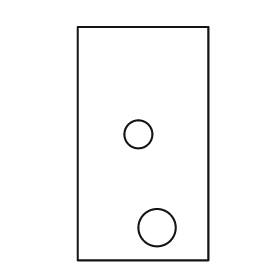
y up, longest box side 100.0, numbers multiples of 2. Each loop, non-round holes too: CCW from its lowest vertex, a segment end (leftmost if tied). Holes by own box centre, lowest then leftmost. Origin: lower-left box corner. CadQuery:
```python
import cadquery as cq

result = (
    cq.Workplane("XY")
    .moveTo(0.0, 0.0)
    .lineTo(56.0, 0.0)
    .lineTo(56.0, 100.0)
    .lineTo(0.0, 100.0)
    .close()
    .moveTo(34.0, 14.0)
    .circle(8.0)
    .moveTo(26.0, 54.0)
    .circle(6.0)
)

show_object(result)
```